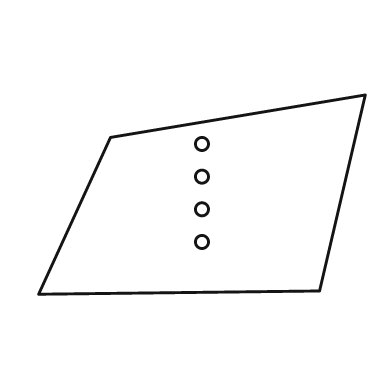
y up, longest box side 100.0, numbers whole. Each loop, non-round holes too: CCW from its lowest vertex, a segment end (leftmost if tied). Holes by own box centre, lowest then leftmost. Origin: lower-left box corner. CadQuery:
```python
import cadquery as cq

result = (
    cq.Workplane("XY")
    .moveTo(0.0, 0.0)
    .lineTo(86.0, 1.0)
    .lineTo(100.0, 61.0)
    .lineTo(22.0, 48.0)
    .close()
    .moveTo(50.0, 16.0)
    .circle(2.0)
    .moveTo(50.0, 26.0)
    .circle(2.0)
    .moveTo(50.0, 36.0)
    .circle(2.0)
    .moveTo(50.0, 46.0)
    .circle(2.0)
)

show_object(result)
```